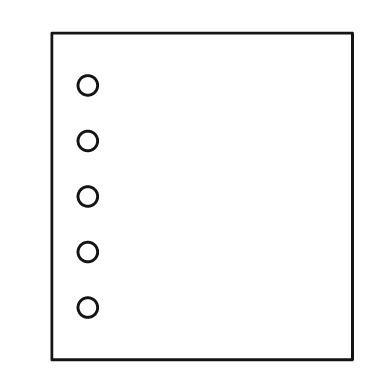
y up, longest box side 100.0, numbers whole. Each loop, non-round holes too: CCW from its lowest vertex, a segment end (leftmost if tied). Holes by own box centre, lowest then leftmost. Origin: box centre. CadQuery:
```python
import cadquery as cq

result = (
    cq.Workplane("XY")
    .moveTo(-46.0, -50.0)
    .lineTo(46.0, -50.0)
    .lineTo(46.0, 50.0)
    .lineTo(-46.0, 50.0)
    .close()
    .moveTo(-35.0, -34.0)
    .circle(3.0)
    .moveTo(-35.0, -17.0)
    .circle(3.0)
    .moveTo(-35.0, 0.0)
    .circle(3.0)
    .moveTo(-35.0, 17.0)
    .circle(3.0)
    .moveTo(-35.0, 34.0)
    .circle(3.0)
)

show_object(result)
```